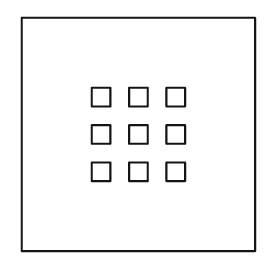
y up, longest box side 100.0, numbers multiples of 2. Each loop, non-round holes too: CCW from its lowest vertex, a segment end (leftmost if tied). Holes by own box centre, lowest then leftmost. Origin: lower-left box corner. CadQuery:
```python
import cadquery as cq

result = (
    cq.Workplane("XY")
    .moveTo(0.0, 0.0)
    .lineTo(100.0, 0.0)
    .lineTo(100.0, 100.0)
    .lineTo(0.0, 100.0)
    .close()
    .moveTo(30.0, 30.0)
    .lineTo(38.0, 30.0)
    .lineTo(38.0, 38.0)
    .lineTo(30.0, 38.0)
    .close()
    .moveTo(46.0, 30.0)
    .lineTo(54.0, 30.0)
    .lineTo(54.0, 38.0)
    .lineTo(46.0, 38.0)
    .close()
    .moveTo(62.0, 30.0)
    .lineTo(70.0, 30.0)
    .lineTo(70.0, 38.0)
    .lineTo(62.0, 38.0)
    .close()
    .moveTo(30.0, 46.0)
    .lineTo(38.0, 46.0)
    .lineTo(38.0, 54.0)
    .lineTo(30.0, 54.0)
    .close()
    .moveTo(46.0, 46.0)
    .lineTo(54.0, 46.0)
    .lineTo(54.0, 54.0)
    .lineTo(46.0, 54.0)
    .close()
    .moveTo(62.0, 46.0)
    .lineTo(70.0, 46.0)
    .lineTo(70.0, 54.0)
    .lineTo(62.0, 54.0)
    .close()
    .moveTo(30.0, 62.0)
    .lineTo(38.0, 62.0)
    .lineTo(38.0, 70.0)
    .lineTo(30.0, 70.0)
    .close()
    .moveTo(46.0, 62.0)
    .lineTo(54.0, 62.0)
    .lineTo(54.0, 70.0)
    .lineTo(46.0, 70.0)
    .close()
    .moveTo(62.0, 62.0)
    .lineTo(70.0, 62.0)
    .lineTo(70.0, 70.0)
    .lineTo(62.0, 70.0)
    .close()
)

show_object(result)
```